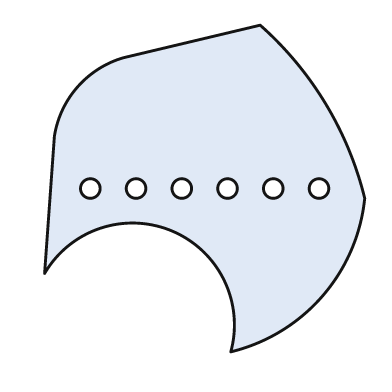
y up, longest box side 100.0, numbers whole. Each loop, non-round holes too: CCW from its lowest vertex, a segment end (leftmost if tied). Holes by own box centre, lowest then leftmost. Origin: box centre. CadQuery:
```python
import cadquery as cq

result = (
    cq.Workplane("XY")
    .moveTo(8.0, -50.0)
    .threePointArc((36.0, -33.0), (49.0, -3.0))
    .threePointArc((37.0, 26.0), (17.0, 50.0))
    .lineTo(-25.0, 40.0)
    .threePointArc((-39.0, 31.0), (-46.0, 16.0))
    .lineTo(-49.0, -26.0)
    .threePointArc((-10.0, -13.0), (8.0, -50.0))
    .close()
    .moveTo(-35.0, 0.0)
    .circle(3.0)
    .moveTo(-21.0, 0.0)
    .circle(3.0)
    .moveTo(-7.0, 0.0)
    .circle(3.0)
    .moveTo(7.0, 0.0)
    .circle(3.0)
    .moveTo(21.0, 0.0)
    .circle(3.0)
    .moveTo(35.0, 0.0)
    .circle(3.0)
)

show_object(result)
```